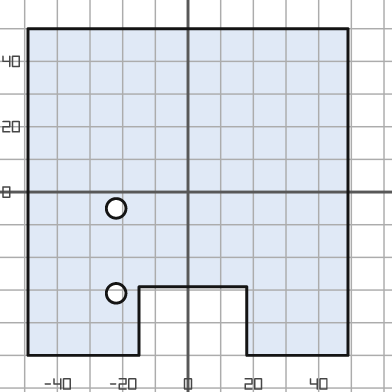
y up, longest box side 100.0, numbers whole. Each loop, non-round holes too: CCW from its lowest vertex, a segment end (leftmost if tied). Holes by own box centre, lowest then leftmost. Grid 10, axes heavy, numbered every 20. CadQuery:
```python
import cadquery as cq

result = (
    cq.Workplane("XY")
    .moveTo(-49.0, -50.0)
    .lineTo(-15.0, -50.0)
    .lineTo(-15.0, -29.0)
    .lineTo(18.0, -29.0)
    .lineTo(18.0, -50.0)
    .lineTo(49.0, -50.0)
    .lineTo(49.0, 50.0)
    .lineTo(-49.0, 50.0)
    .close()
    .moveTo(-22.0, -31.0)
    .circle(3.0)
    .moveTo(-22.0, -5.0)
    .circle(3.0)
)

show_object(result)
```